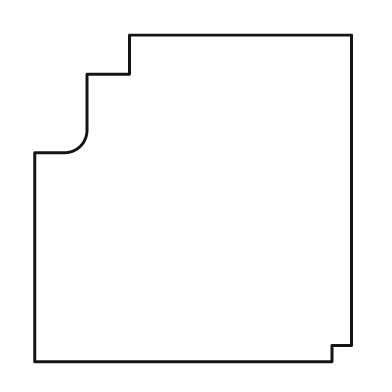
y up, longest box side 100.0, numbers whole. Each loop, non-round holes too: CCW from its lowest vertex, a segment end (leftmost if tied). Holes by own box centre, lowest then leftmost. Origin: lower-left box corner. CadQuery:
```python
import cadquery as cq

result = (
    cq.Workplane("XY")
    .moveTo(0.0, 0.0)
    .lineTo(91.0, 0.0)
    .lineTo(91.0, 5.0)
    .lineTo(97.0, 5.0)
    .lineTo(97.0, 100.0)
    .lineTo(29.0, 100.0)
    .lineTo(29.0, 88.0)
    .lineTo(16.0, 88.0)
    .lineTo(16.0, 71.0)
    .threePointArc((14.0, 66.0), (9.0, 64.0))
    .lineTo(0.0, 64.0)
    .close()
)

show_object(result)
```